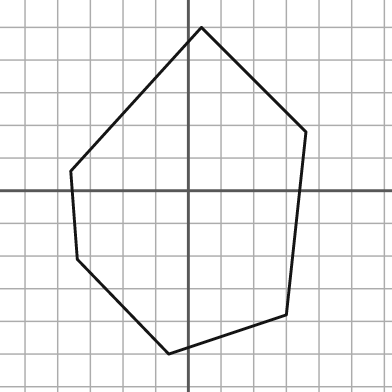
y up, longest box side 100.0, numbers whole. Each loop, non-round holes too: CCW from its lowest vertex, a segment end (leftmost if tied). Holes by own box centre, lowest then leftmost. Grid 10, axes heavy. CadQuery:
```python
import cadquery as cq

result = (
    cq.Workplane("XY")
    .moveTo(-6.0, -50.0)
    .lineTo(30.0, -38.0)
    .lineTo(36.0, 18.0)
    .lineTo(4.0, 50.0)
    .lineTo(-36.0, 6.0)
    .lineTo(-34.0, -21.0)
    .close()
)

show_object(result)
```